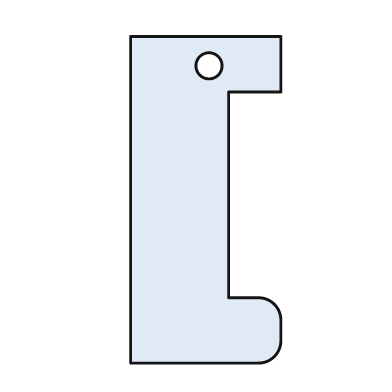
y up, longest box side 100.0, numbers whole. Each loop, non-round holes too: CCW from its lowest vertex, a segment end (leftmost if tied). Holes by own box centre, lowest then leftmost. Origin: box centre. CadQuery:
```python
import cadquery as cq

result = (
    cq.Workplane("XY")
    .moveTo(-23.0, -50.0)
    .lineTo(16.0, -50.0)
    .threePointArc((21.0, -48.0), (23.0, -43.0))
    .lineTo(23.0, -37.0)
    .threePointArc((21.0, -32.0), (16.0, -30.0))
    .lineTo(7.0, -30.0)
    .lineTo(7.0, 33.0)
    .lineTo(23.0, 33.0)
    .lineTo(23.0, 50.0)
    .lineTo(-23.0, 50.0)
    .close()
    .moveTo(1.0, 41.0)
    .circle(4.0)
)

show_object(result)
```